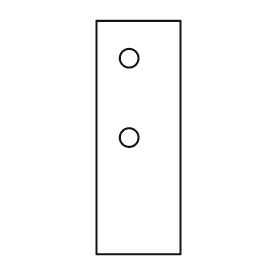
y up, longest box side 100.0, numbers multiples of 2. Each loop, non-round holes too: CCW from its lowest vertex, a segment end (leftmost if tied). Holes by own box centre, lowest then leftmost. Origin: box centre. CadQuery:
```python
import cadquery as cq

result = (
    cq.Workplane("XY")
    .moveTo(-18.0, -50.0)
    .lineTo(18.0, -50.0)
    .lineTo(18.0, 50.0)
    .lineTo(-18.0, 50.0)
    .close()
    .moveTo(-4.0, 0.0)
    .circle(4.0)
    .moveTo(-4.0, 34.0)
    .circle(4.0)
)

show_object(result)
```